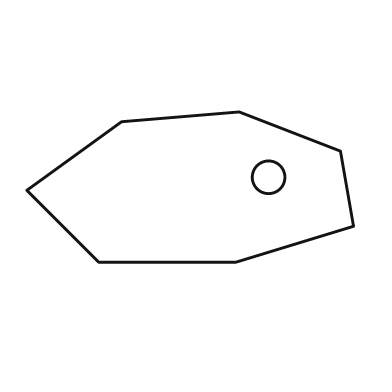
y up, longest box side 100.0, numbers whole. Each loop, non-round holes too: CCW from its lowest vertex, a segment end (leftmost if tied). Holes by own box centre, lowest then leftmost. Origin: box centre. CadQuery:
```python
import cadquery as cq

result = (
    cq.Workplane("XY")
    .moveTo(-28.0, -23.0)
    .lineTo(14.0, -23.0)
    .lineTo(50.0, -12.0)
    .lineTo(46.0, 11.0)
    .lineTo(15.0, 23.0)
    .lineTo(-21.0, 20.0)
    .lineTo(-50.0, -1.0)
    .close()
    .moveTo(24.0, 3.0)
    .circle(5.0)
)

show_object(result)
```